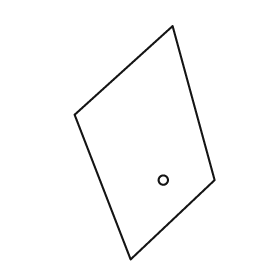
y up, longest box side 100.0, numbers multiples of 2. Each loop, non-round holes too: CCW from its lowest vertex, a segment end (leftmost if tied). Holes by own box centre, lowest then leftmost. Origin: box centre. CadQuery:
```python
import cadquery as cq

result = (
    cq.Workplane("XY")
    .moveTo(-6.0, -50.0)
    .lineTo(30.0, -16.0)
    .lineTo(12.0, 50.0)
    .lineTo(-30.0, 12.0)
    .close()
    .moveTo(8.0, -16.0)
    .circle(2.0)
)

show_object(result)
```